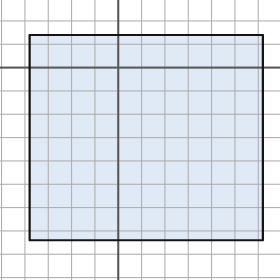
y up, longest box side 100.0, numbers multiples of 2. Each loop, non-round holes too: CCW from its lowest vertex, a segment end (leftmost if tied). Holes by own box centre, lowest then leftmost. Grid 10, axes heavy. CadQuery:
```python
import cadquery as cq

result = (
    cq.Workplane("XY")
    .moveTo(-38.0, -74.0)
    .lineTo(62.0, -74.0)
    .lineTo(62.0, 14.0)
    .lineTo(-38.0, 14.0)
    .close()
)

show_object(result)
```